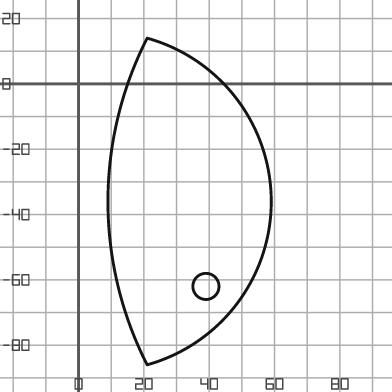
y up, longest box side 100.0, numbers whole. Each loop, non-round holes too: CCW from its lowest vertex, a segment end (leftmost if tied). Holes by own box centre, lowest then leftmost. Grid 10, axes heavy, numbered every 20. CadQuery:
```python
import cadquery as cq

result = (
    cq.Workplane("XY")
    .moveTo(21.0, -86.0)
    .threePointArc((59.0, -36.0), (21.0, 14.0))
    .threePointArc((9.0, -36.0), (21.0, -86.0))
    .close()
    .moveTo(39.0, -62.0)
    .circle(4.0)
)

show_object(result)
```